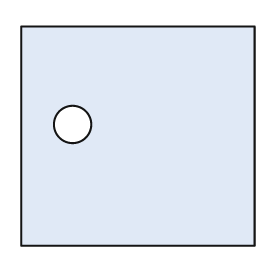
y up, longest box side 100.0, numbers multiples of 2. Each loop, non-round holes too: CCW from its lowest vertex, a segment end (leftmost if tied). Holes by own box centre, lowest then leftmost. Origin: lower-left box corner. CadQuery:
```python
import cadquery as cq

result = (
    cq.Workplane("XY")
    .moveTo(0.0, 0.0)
    .lineTo(100.0, 0.0)
    .lineTo(100.0, 94.0)
    .lineTo(0.0, 94.0)
    .close()
    .moveTo(22.0, 52.0)
    .circle(8.0)
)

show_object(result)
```